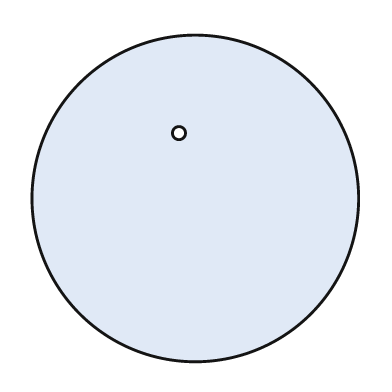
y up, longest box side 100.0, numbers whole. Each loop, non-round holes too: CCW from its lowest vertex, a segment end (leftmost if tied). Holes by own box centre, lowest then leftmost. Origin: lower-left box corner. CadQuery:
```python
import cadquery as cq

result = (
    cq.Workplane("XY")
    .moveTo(50.0, 50.0)
    .circle(50.0)
    .moveTo(45.0, 70.0)
    .circle(2.0)
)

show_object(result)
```